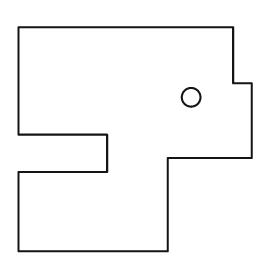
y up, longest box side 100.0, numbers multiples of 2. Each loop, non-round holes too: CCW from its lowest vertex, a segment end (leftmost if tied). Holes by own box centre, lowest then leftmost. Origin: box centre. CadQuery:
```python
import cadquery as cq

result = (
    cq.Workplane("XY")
    .moveTo(-50.0, -48.0)
    .lineTo(14.0, -48.0)
    .lineTo(14.0, -8.0)
    .lineTo(50.0, -8.0)
    .lineTo(50.0, 24.0)
    .lineTo(42.0, 24.0)
    .lineTo(42.0, 48.0)
    .lineTo(-50.0, 48.0)
    .lineTo(-50.0, 2.0)
    .lineTo(-12.0, 2.0)
    .lineTo(-12.0, -14.0)
    .lineTo(-50.0, -14.0)
    .close()
    .moveTo(24.0, 18.0)
    .circle(4.0)
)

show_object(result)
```